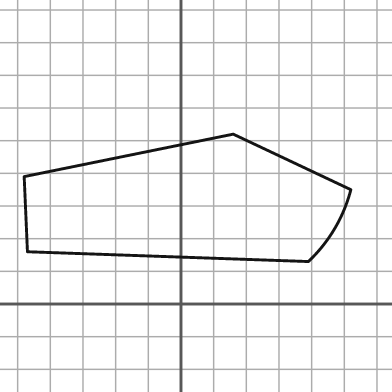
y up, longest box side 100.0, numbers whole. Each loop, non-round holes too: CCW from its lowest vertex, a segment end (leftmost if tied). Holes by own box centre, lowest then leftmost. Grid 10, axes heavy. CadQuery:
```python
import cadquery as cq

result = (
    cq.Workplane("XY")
    .moveTo(39.0, 13.0)
    .threePointArc((47.0, 23.0), (52.0, 35.0))
    .lineTo(16.0, 52.0)
    .lineTo(-48.0, 39.0)
    .lineTo(-47.0, 16.0)
    .close()
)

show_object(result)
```